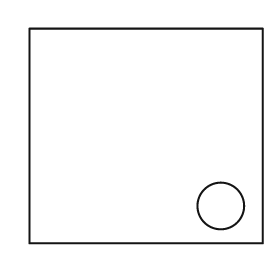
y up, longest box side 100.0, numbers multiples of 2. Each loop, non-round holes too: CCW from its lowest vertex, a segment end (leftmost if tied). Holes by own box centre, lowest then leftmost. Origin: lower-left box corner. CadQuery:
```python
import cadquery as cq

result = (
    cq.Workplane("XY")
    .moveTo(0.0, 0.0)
    .lineTo(100.0, 0.0)
    .lineTo(100.0, 92.0)
    .lineTo(0.0, 92.0)
    .close()
    .moveTo(82.0, 16.0)
    .circle(10.0)
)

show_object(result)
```